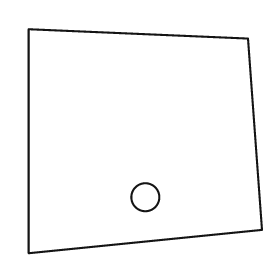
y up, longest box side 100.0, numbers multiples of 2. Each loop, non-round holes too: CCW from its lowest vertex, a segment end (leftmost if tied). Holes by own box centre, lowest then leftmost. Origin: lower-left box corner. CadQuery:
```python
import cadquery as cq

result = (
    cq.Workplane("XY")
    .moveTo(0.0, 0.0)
    .lineTo(100.0, 10.0)
    .lineTo(94.0, 92.0)
    .lineTo(0.0, 96.0)
    .close()
    .moveTo(50.0, 24.0)
    .circle(6.0)
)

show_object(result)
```